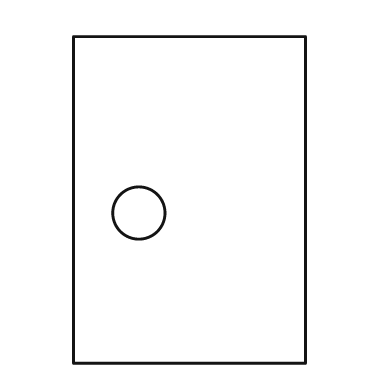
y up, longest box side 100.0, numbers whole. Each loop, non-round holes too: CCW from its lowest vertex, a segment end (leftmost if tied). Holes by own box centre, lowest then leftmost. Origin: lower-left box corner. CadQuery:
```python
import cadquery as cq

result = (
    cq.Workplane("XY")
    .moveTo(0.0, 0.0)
    .lineTo(71.0, 0.0)
    .lineTo(71.0, 100.0)
    .lineTo(0.0, 100.0)
    .close()
    .moveTo(20.0, 46.0)
    .circle(8.0)
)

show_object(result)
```